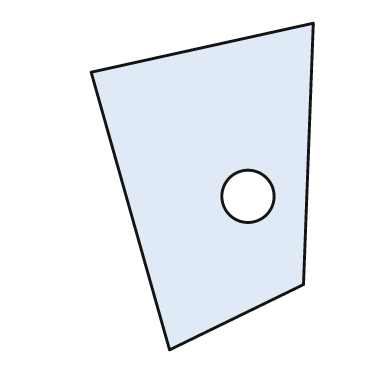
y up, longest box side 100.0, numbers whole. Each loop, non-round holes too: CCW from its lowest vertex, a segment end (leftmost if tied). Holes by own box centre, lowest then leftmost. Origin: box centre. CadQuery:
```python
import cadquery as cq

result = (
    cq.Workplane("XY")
    .moveTo(-10.0, -50.0)
    .lineTo(31.0, -30.0)
    .lineTo(34.0, 50.0)
    .lineTo(-34.0, 35.0)
    .close()
    .moveTo(14.0, -3.0)
    .circle(8.0)
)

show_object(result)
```